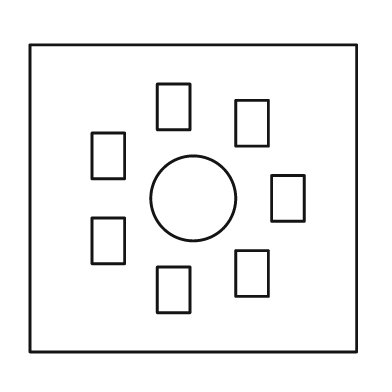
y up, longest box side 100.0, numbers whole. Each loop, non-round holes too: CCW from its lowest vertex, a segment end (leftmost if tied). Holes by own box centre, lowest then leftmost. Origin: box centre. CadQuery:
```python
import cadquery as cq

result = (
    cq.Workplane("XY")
    .moveTo(-50.0, -47.0)
    .lineTo(50.0, -47.0)
    .lineTo(50.0, 47.0)
    .lineTo(-50.0, 47.0)
    .close()
    .moveTo(-11.0, -35.0)
    .lineTo(-1.0, -35.0)
    .lineTo(-1.0, -21.0)
    .lineTo(-11.0, -21.0)
    .close()
    .moveTo(13.0, -30.0)
    .lineTo(23.0, -30.0)
    .lineTo(23.0, -16.0)
    .lineTo(13.0, -16.0)
    .close()
    .moveTo(-31.0, -20.0)
    .lineTo(-21.0, -20.0)
    .lineTo(-21.0, -6.0)
    .lineTo(-31.0, -6.0)
    .close()
    .moveTo(0.0, 0.0)
    .circle(13.0)
    .moveTo(24.0, -7.0)
    .lineTo(34.0, -7.0)
    .lineTo(34.0, 7.0)
    .lineTo(24.0, 7.0)
    .close()
    .moveTo(-31.0, 6.0)
    .lineTo(-21.0, 6.0)
    .lineTo(-21.0, 20.0)
    .lineTo(-31.0, 20.0)
    .close()
    .moveTo(13.0, 16.0)
    .lineTo(23.0, 16.0)
    .lineTo(23.0, 30.0)
    .lineTo(13.0, 30.0)
    .close()
    .moveTo(-11.0, 21.0)
    .lineTo(-1.0, 21.0)
    .lineTo(-1.0, 35.0)
    .lineTo(-11.0, 35.0)
    .close()
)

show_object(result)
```